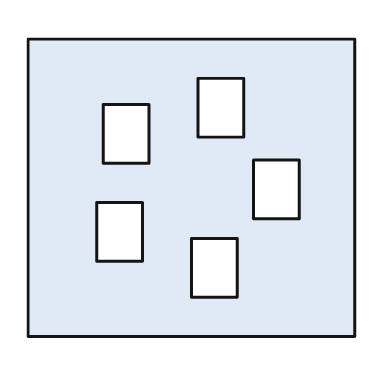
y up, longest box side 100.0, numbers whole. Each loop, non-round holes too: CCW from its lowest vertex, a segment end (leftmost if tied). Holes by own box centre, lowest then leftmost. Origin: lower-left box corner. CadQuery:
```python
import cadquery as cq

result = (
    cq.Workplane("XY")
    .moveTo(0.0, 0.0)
    .lineTo(100.0, 0.0)
    .lineTo(100.0, 91.0)
    .lineTo(0.0, 91.0)
    .close()
    .moveTo(50.0, 12.0)
    .lineTo(64.0, 12.0)
    .lineTo(64.0, 30.0)
    .lineTo(50.0, 30.0)
    .close()
    .moveTo(21.0, 23.0)
    .lineTo(35.0, 23.0)
    .lineTo(35.0, 41.0)
    .lineTo(21.0, 41.0)
    .close()
    .moveTo(69.0, 36.0)
    .lineTo(83.0, 36.0)
    .lineTo(83.0, 54.0)
    .lineTo(69.0, 54.0)
    .close()
    .moveTo(23.0, 53.0)
    .lineTo(37.0, 53.0)
    .lineTo(37.0, 71.0)
    .lineTo(23.0, 71.0)
    .close()
    .moveTo(52.0, 61.0)
    .lineTo(66.0, 61.0)
    .lineTo(66.0, 79.0)
    .lineTo(52.0, 79.0)
    .close()
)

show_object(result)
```